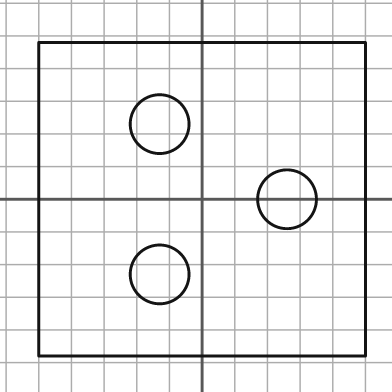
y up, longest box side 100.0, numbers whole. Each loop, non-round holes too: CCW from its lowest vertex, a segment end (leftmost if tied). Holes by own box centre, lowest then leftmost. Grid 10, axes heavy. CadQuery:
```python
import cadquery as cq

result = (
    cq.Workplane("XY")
    .moveTo(-50.0, -48.0)
    .lineTo(50.0, -48.0)
    .lineTo(50.0, 48.0)
    .lineTo(-50.0, 48.0)
    .close()
    .moveTo(-13.0, -23.0)
    .circle(9.0)
    .moveTo(26.0, 0.0)
    .circle(9.0)
    .moveTo(-13.0, 23.0)
    .circle(9.0)
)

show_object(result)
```